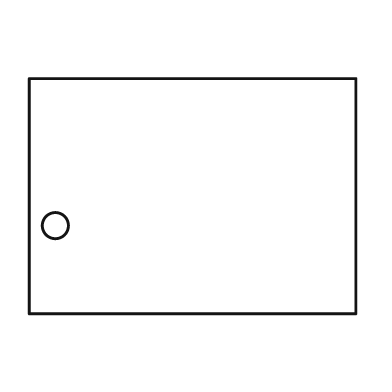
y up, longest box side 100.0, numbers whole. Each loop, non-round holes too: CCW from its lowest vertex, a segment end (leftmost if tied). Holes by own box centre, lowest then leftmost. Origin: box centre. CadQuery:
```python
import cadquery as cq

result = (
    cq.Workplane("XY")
    .moveTo(-50.0, -36.0)
    .lineTo(50.0, -36.0)
    .lineTo(50.0, 36.0)
    .lineTo(-50.0, 36.0)
    .close()
    .moveTo(-42.0, -9.0)
    .circle(4.0)
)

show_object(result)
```